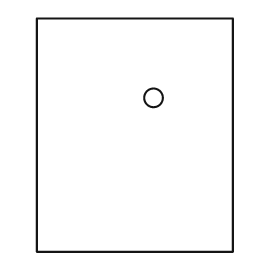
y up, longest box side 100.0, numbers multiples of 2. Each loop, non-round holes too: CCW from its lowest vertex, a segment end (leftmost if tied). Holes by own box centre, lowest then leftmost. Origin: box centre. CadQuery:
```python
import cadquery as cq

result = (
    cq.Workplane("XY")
    .moveTo(-42.0, -50.0)
    .lineTo(42.0, -50.0)
    .lineTo(42.0, 50.0)
    .lineTo(-42.0, 50.0)
    .close()
    .moveTo(8.0, 16.0)
    .circle(4.0)
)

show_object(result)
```